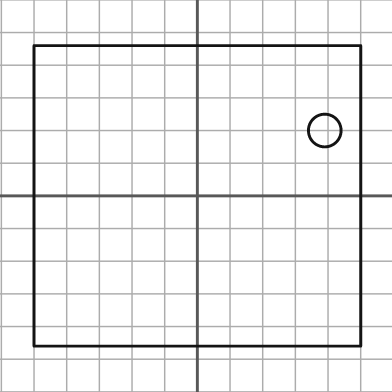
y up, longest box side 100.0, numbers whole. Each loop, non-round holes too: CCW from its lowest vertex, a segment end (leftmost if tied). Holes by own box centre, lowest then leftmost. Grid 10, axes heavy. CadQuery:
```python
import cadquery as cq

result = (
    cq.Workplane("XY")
    .moveTo(-50.0, -46.0)
    .lineTo(50.0, -46.0)
    .lineTo(50.0, 46.0)
    .lineTo(-50.0, 46.0)
    .close()
    .moveTo(39.0, 20.0)
    .circle(5.0)
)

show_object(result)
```